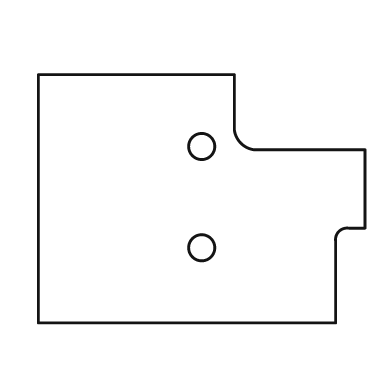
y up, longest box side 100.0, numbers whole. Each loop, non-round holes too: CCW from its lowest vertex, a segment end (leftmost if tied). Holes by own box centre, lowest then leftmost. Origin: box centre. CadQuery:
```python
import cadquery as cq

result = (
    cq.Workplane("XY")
    .moveTo(-50.0, -38.0)
    .lineTo(41.0, -38.0)
    .lineTo(41.0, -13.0)
    .threePointArc((42.0, -10.0), (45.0, -9.0))
    .lineTo(50.0, -9.0)
    .lineTo(50.0, 15.0)
    .lineTo(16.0, 15.0)
    .threePointArc((12.0, 17.0), (10.0, 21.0))
    .lineTo(10.0, 38.0)
    .lineTo(-50.0, 38.0)
    .close()
    .moveTo(0.0, -15.0)
    .circle(4.0)
    .moveTo(0.0, 16.0)
    .circle(4.0)
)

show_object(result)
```